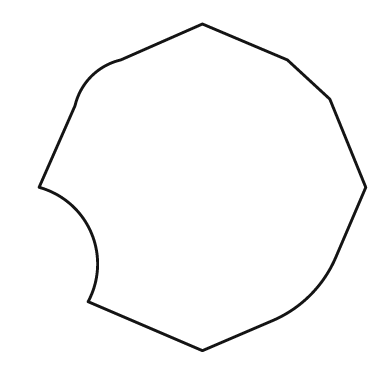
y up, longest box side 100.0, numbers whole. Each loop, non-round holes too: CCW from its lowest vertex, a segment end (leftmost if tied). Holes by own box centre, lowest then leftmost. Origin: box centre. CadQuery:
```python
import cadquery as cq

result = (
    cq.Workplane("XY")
    .moveTo(0.0, -50.0)
    .lineTo(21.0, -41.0)
    .threePointArc((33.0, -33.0), (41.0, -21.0))
    .lineTo(50.0, 0.0)
    .lineTo(39.0, 27.0)
    .lineTo(26.0, 39.0)
    .lineTo(0.0, 50.0)
    .lineTo(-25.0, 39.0)
    .threePointArc((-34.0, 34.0), (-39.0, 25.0))
    .lineTo(-50.0, 0.0)
    .threePointArc((-34.0, -14.0), (-35.0, -35.0))
    .close()
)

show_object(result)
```